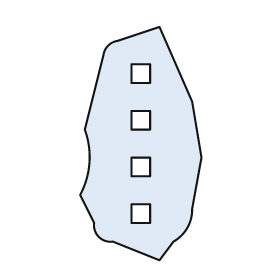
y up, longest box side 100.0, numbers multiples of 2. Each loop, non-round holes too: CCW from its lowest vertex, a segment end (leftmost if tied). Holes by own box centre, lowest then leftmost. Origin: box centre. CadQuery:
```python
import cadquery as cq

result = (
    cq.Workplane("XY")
    .moveTo(8.0, -50.0)
    .lineTo(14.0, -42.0)
    .threePointArc((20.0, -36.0), (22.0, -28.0))
    .lineTo(26.0, -6.0)
    .lineTo(22.0, 18.0)
    .lineTo(8.0, 50.0)
    .lineTo(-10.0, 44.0)
    .threePointArc((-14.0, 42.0), (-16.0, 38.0))
    .lineTo(-24.0, 6.0)
    .threePointArc((-22.0, -8.0), (-26.0, -22.0))
    .lineTo(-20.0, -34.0)
    .threePointArc((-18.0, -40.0), (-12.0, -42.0))
    .close()
    .moveTo(-4.0, -34.0)
    .lineTo(4.0, -34.0)
    .lineTo(4.0, -26.0)
    .lineTo(-4.0, -26.0)
    .close()
    .moveTo(-4.0, -14.0)
    .lineTo(4.0, -14.0)
    .lineTo(4.0, -6.0)
    .lineTo(-4.0, -6.0)
    .close()
    .moveTo(-4.0, 6.0)
    .lineTo(4.0, 6.0)
    .lineTo(4.0, 14.0)
    .lineTo(-4.0, 14.0)
    .close()
    .moveTo(-4.0, 26.0)
    .lineTo(4.0, 26.0)
    .lineTo(4.0, 34.0)
    .lineTo(-4.0, 34.0)
    .close()
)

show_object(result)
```